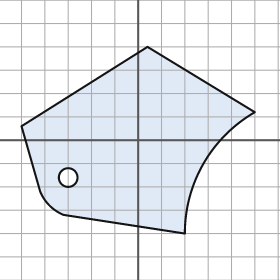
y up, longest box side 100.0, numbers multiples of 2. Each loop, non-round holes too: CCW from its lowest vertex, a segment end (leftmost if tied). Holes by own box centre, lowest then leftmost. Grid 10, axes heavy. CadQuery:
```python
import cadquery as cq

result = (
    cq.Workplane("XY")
    .moveTo(20.0, -40.0)
    .threePointArc((28.0, -10.0), (50.0, 12.0))
    .lineTo(4.0, 40.0)
    .lineTo(-50.0, 6.0)
    .lineTo(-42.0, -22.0)
    .threePointArc((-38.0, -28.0), (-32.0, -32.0))
    .close()
    .moveTo(-30.0, -16.0)
    .circle(4.0)
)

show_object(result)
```